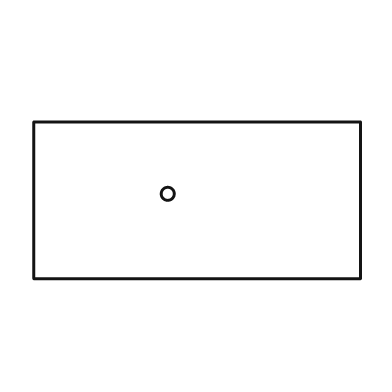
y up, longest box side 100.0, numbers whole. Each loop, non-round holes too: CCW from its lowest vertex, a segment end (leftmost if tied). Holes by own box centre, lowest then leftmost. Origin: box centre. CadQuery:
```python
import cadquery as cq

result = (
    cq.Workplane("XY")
    .moveTo(-50.0, -24.0)
    .lineTo(50.0, -24.0)
    .lineTo(50.0, 24.0)
    .lineTo(-50.0, 24.0)
    .close()
    .moveTo(-9.0, 2.0)
    .circle(2.0)
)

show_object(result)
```